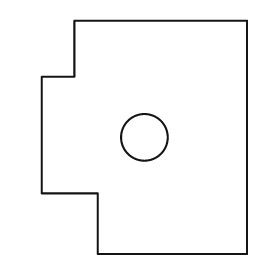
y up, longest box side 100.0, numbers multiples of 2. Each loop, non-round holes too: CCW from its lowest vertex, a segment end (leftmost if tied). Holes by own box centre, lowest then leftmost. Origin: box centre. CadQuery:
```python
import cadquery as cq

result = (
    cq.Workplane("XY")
    .moveTo(-20.0, -50.0)
    .lineTo(44.0, -50.0)
    .lineTo(44.0, 50.0)
    .lineTo(-30.0, 50.0)
    .lineTo(-30.0, 26.0)
    .lineTo(-44.0, 26.0)
    .lineTo(-44.0, -24.0)
    .lineTo(-20.0, -24.0)
    .close()
    .moveTo(0.0, 0.0)
    .circle(10.0)
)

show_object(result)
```